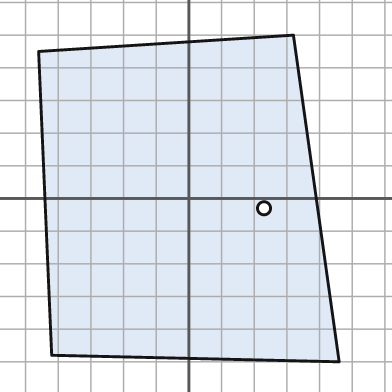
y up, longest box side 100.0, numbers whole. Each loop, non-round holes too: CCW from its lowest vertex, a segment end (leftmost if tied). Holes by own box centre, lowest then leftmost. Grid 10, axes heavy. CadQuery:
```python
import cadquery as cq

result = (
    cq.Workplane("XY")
    .moveTo(46.0, -50.0)
    .lineTo(32.0, 50.0)
    .lineTo(-46.0, 45.0)
    .lineTo(-42.0, -48.0)
    .close()
    .moveTo(23.0, -3.0)
    .circle(2.0)
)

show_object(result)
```